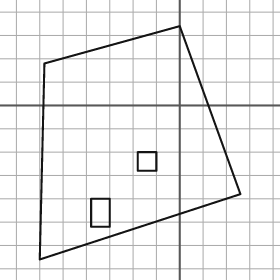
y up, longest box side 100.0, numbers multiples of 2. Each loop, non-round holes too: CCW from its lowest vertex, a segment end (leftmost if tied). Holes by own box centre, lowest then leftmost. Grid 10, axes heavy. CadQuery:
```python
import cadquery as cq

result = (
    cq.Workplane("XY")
    .moveTo(-60.0, -66.0)
    .lineTo(26.0, -38.0)
    .lineTo(0.0, 34.0)
    .lineTo(-58.0, 18.0)
    .close()
    .moveTo(-38.0, -52.0)
    .lineTo(-30.0, -52.0)
    .lineTo(-30.0, -40.0)
    .lineTo(-38.0, -40.0)
    .close()
    .moveTo(-18.0, -28.0)
    .lineTo(-10.0, -28.0)
    .lineTo(-10.0, -20.0)
    .lineTo(-18.0, -20.0)
    .close()
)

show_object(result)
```